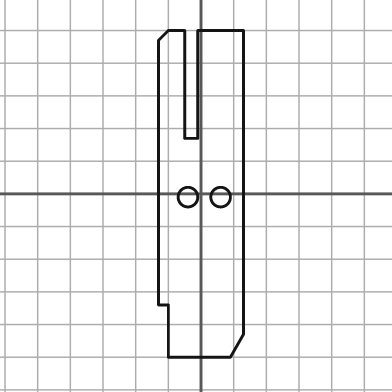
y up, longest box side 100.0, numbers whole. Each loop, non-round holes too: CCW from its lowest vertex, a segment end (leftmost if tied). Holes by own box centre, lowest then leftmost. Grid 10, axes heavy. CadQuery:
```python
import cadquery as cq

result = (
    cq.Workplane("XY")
    .moveTo(-10.0, -50.0)
    .lineTo(9.0, -50.0)
    .lineTo(13.0, -43.0)
    .lineTo(13.0, 50.0)
    .lineTo(-1.0, 50.0)
    .lineTo(-1.0, 17.0)
    .lineTo(-5.0, 17.0)
    .lineTo(-5.0, 50.0)
    .lineTo(-10.0, 50.0)
    .lineTo(-13.0, 47.0)
    .lineTo(-13.0, -34.0)
    .lineTo(-10.0, -34.0)
    .close()
    .moveTo(-4.0, -1.0)
    .circle(3.0)
    .moveTo(6.0, -1.0)
    .circle(3.0)
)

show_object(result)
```